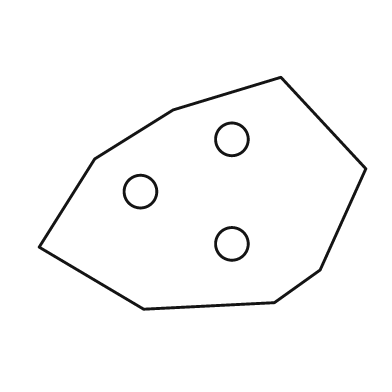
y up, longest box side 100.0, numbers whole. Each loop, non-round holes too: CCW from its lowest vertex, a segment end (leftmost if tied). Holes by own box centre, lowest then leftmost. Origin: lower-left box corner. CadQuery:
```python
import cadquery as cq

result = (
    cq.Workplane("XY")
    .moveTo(32.0, 0.0)
    .lineTo(72.0, 2.0)
    .lineTo(86.0, 12.0)
    .lineTo(100.0, 43.0)
    .lineTo(74.0, 71.0)
    .lineTo(41.0, 61.0)
    .lineTo(17.0, 46.0)
    .lineTo(0.0, 19.0)
    .close()
    .moveTo(59.0, 20.0)
    .circle(5.0)
    .moveTo(31.0, 36.0)
    .circle(5.0)
    .moveTo(59.0, 52.0)
    .circle(5.0)
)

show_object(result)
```